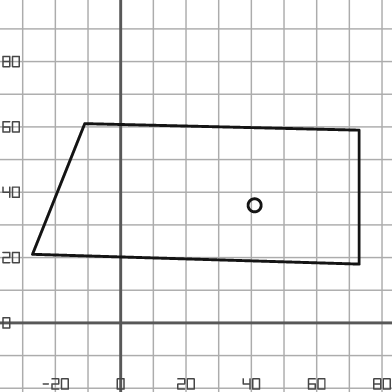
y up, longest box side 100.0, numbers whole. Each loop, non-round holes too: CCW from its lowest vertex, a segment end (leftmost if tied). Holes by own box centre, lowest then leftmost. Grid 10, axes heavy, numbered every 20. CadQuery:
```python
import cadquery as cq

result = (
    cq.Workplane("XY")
    .moveTo(73.0, 18.0)
    .lineTo(73.0, 59.0)
    .lineTo(-11.0, 61.0)
    .lineTo(-27.0, 21.0)
    .close()
    .moveTo(41.0, 36.0)
    .circle(2.0)
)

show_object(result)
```